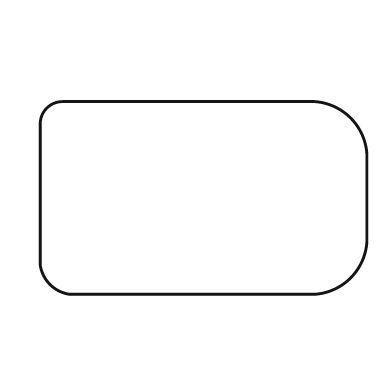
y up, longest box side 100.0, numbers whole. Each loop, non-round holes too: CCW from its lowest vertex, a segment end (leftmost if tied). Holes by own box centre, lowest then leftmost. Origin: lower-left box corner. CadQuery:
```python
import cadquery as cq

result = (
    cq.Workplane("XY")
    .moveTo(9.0, 0.0)
    .lineTo(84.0, 0.0)
    .threePointArc((95.0, 5.0), (100.0, 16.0))
    .lineTo(100.0, 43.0)
    .threePointArc((95.0, 54.0), (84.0, 59.0))
    .lineTo(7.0, 59.0)
    .threePointArc((2.0, 57.0), (0.0, 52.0))
    .lineTo(0.0, 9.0)
    .threePointArc((3.0, 3.0), (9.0, 0.0))
    .close()
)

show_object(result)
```